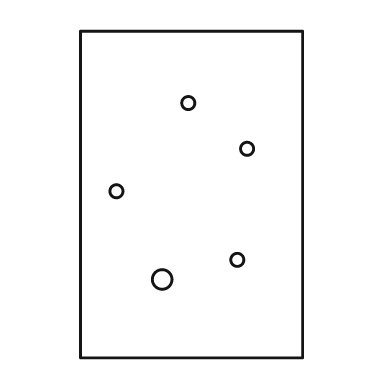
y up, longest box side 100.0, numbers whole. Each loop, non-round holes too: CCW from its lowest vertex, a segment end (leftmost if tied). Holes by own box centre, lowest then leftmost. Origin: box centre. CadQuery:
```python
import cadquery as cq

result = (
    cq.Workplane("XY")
    .moveTo(-34.0, -50.0)
    .lineTo(34.0, -50.0)
    .lineTo(34.0, 50.0)
    .lineTo(-34.0, 50.0)
    .close()
    .moveTo(-9.0, -26.0)
    .circle(3.0)
    .moveTo(14.0, -20.0)
    .circle(2.0)
    .moveTo(-23.0, 1.0)
    .circle(2.0)
    .moveTo(17.0, 14.0)
    .circle(2.0)
    .moveTo(-1.0, 28.0)
    .circle(2.0)
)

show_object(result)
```